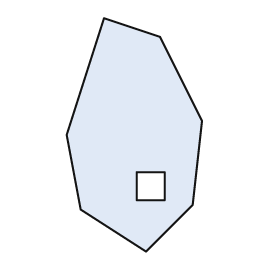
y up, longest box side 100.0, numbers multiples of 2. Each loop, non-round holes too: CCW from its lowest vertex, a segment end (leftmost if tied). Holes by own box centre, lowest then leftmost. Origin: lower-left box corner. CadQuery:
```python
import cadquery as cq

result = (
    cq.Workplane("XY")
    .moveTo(34.0, 0.0)
    .lineTo(54.0, 20.0)
    .lineTo(58.0, 56.0)
    .lineTo(40.0, 92.0)
    .lineTo(16.0, 100.0)
    .lineTo(0.0, 50.0)
    .lineTo(6.0, 18.0)
    .close()
    .moveTo(30.0, 22.0)
    .lineTo(42.0, 22.0)
    .lineTo(42.0, 34.0)
    .lineTo(30.0, 34.0)
    .close()
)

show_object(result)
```